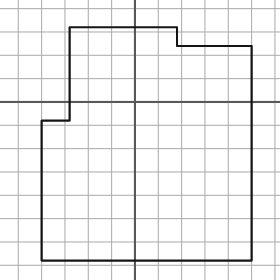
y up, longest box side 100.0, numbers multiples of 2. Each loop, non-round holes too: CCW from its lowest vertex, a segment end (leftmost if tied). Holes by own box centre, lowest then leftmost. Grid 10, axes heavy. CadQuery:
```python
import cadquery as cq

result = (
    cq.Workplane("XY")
    .moveTo(-40.0, -68.0)
    .lineTo(50.0, -68.0)
    .lineTo(50.0, 24.0)
    .lineTo(18.0, 24.0)
    .lineTo(18.0, 32.0)
    .lineTo(-28.0, 32.0)
    .lineTo(-28.0, -8.0)
    .lineTo(-40.0, -8.0)
    .close()
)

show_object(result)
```